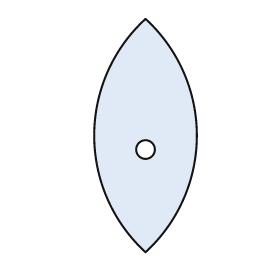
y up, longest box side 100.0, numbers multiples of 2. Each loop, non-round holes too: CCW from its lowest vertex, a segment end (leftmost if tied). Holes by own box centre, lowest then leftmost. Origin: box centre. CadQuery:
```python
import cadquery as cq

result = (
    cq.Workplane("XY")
    .moveTo(0.0, -50.0)
    .threePointArc((22.0, 0.0), (0.0, 50.0))
    .threePointArc((-22.0, 0.0), (0.0, -50.0))
    .close()
    .moveTo(0.0, -6.0)
    .circle(4.0)
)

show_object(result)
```